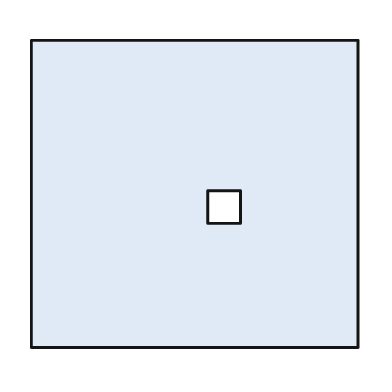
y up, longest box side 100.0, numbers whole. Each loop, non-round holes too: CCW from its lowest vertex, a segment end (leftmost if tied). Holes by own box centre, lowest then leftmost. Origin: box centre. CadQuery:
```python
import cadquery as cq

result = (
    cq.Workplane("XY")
    .moveTo(-50.0, -47.0)
    .lineTo(50.0, -47.0)
    .lineTo(50.0, 47.0)
    .lineTo(-50.0, 47.0)
    .close()
    .moveTo(4.0, -9.0)
    .lineTo(14.0, -9.0)
    .lineTo(14.0, 1.0)
    .lineTo(4.0, 1.0)
    .close()
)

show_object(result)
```